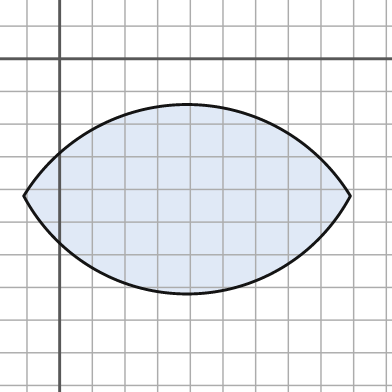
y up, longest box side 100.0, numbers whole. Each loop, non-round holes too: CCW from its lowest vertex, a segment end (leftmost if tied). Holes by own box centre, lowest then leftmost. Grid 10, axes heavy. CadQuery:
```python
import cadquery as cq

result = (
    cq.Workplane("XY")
    .moveTo(-11.0, -42.0)
    .threePointArc((39.0, -72.0), (89.0, -42.0))
    .threePointArc((39.0, -14.0), (-11.0, -42.0))
    .close()
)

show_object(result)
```